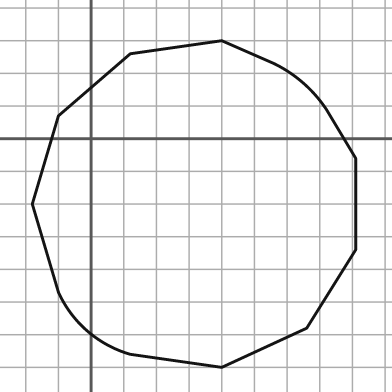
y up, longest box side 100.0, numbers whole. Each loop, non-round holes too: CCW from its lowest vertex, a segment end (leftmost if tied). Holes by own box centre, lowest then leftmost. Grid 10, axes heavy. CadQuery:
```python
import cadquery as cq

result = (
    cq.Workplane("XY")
    .moveTo(40.0, -70.0)
    .lineTo(66.0, -58.0)
    .lineTo(81.0, -34.0)
    .lineTo(81.0, -6.0)
    .lineTo(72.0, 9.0)
    .threePointArc((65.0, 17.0), (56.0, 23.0))
    .lineTo(40.0, 30.0)
    .lineTo(12.0, 26.0)
    .lineTo(-10.0, 7.0)
    .lineTo(-18.0, -20.0)
    .lineTo(-10.0, -47.0)
    .threePointArc((-1.0, -59.0), (12.0, -66.0))
    .close()
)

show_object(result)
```